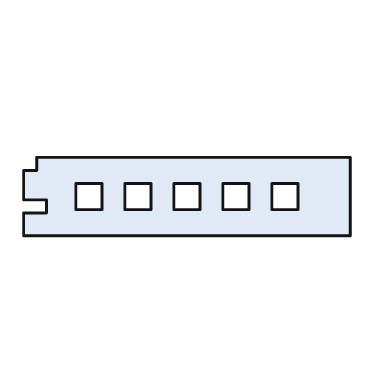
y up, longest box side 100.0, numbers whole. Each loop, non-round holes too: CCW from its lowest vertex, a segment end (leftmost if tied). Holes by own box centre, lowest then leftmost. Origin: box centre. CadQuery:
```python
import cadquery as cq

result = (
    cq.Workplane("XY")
    .moveTo(-50.0, -12.0)
    .lineTo(50.0, -12.0)
    .lineTo(50.0, 12.0)
    .lineTo(-46.0, 12.0)
    .lineTo(-46.0, 8.0)
    .lineTo(-50.0, 8.0)
    .lineTo(-50.0, -1.0)
    .lineTo(-43.0, -1.0)
    .lineTo(-43.0, -5.0)
    .lineTo(-50.0, -5.0)
    .close()
    .moveTo(-34.0, -4.0)
    .lineTo(-26.0, -4.0)
    .lineTo(-26.0, 4.0)
    .lineTo(-34.0, 4.0)
    .close()
    .moveTo(-19.0, -4.0)
    .lineTo(-11.0, -4.0)
    .lineTo(-11.0, 4.0)
    .lineTo(-19.0, 4.0)
    .close()
    .moveTo(-4.0, -4.0)
    .lineTo(4.0, -4.0)
    .lineTo(4.0, 4.0)
    .lineTo(-4.0, 4.0)
    .close()
    .moveTo(11.0, -4.0)
    .lineTo(19.0, -4.0)
    .lineTo(19.0, 4.0)
    .lineTo(11.0, 4.0)
    .close()
    .moveTo(26.0, -4.0)
    .lineTo(34.0, -4.0)
    .lineTo(34.0, 4.0)
    .lineTo(26.0, 4.0)
    .close()
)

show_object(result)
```